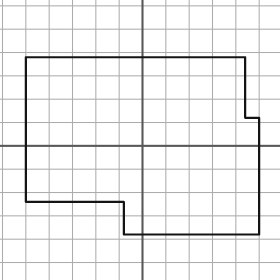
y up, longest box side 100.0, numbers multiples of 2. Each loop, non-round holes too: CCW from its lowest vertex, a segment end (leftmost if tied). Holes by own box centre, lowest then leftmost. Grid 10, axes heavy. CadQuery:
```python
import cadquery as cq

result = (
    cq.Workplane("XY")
    .moveTo(-8.0, -38.0)
    .lineTo(50.0, -38.0)
    .lineTo(50.0, 12.0)
    .lineTo(44.0, 12.0)
    .lineTo(44.0, 38.0)
    .lineTo(-50.0, 38.0)
    .lineTo(-50.0, -24.0)
    .lineTo(-8.0, -24.0)
    .close()
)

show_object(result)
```